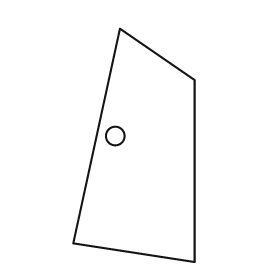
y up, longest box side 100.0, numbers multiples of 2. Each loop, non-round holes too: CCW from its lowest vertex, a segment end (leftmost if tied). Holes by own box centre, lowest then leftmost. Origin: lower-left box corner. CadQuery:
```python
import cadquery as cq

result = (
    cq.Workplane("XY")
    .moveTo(52.0, 0.0)
    .lineTo(52.0, 78.0)
    .lineTo(20.0, 100.0)
    .lineTo(0.0, 8.0)
    .close()
    .moveTo(18.0, 54.0)
    .circle(4.0)
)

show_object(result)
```